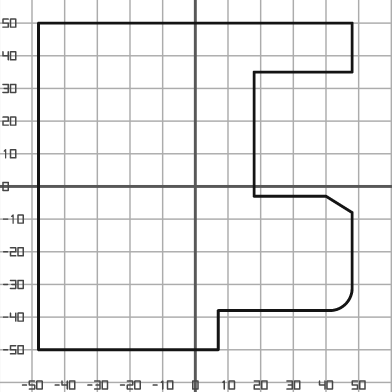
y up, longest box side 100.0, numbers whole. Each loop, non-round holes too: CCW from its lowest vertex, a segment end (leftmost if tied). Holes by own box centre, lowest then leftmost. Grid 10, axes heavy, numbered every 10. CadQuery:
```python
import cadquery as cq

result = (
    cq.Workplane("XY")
    .moveTo(-48.0, -50.0)
    .lineTo(7.0, -50.0)
    .lineTo(7.0, -38.0)
    .lineTo(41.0, -38.0)
    .threePointArc((46.0, -36.0), (48.0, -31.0))
    .lineTo(48.0, -8.0)
    .lineTo(40.0, -3.0)
    .lineTo(18.0, -3.0)
    .lineTo(18.0, 35.0)
    .lineTo(48.0, 35.0)
    .lineTo(48.0, 50.0)
    .lineTo(-48.0, 50.0)
    .close()
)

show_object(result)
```